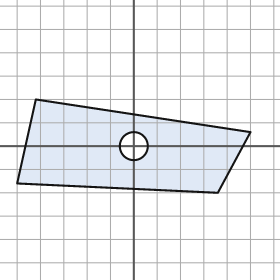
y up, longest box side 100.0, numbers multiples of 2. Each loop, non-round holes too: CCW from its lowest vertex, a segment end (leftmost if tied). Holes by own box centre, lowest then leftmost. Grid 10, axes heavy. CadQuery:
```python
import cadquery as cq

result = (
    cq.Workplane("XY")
    .moveTo(36.0, -20.0)
    .lineTo(50.0, 6.0)
    .lineTo(-42.0, 20.0)
    .lineTo(-50.0, -16.0)
    .close()
    .moveTo(0.0, 0.0)
    .circle(6.0)
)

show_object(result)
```